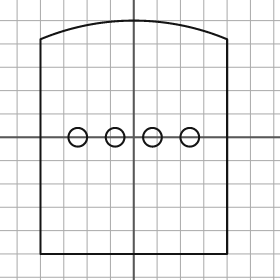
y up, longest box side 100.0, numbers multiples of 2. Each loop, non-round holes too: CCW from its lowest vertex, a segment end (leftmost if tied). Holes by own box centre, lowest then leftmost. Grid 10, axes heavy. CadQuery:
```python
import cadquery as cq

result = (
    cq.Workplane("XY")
    .moveTo(-40.0, -50.0)
    .lineTo(40.0, -50.0)
    .lineTo(40.0, 42.0)
    .threePointArc((0.0, 50.0), (-40.0, 42.0))
    .close()
    .moveTo(-24.0, 0.0)
    .circle(4.0)
    .moveTo(-8.0, 0.0)
    .circle(4.0)
    .moveTo(8.0, 0.0)
    .circle(4.0)
    .moveTo(24.0, 0.0)
    .circle(4.0)
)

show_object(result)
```